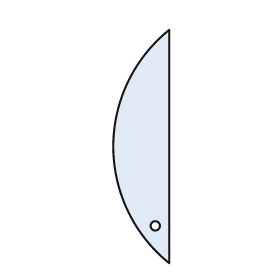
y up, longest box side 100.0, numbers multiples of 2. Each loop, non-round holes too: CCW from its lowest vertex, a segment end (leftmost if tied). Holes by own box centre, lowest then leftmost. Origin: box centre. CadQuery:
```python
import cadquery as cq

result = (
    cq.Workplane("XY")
    .moveTo(12.0, -50.0)
    .lineTo(12.0, 50.0)
    .threePointArc((-12.0, 0.0), (12.0, -50.0))
    .close()
    .moveTo(6.0, -34.0)
    .circle(2.0)
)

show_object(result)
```